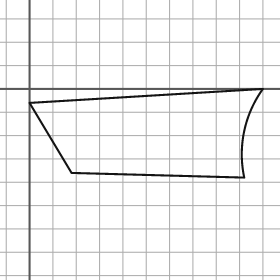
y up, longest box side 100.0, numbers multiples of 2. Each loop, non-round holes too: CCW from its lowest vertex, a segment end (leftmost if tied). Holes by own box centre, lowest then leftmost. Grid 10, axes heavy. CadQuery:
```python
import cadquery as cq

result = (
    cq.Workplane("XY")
    .moveTo(92.0, -38.0)
    .threePointArc((92.0, -18.0), (100.0, 0.0))
    .lineTo(0.0, -6.0)
    .lineTo(18.0, -36.0)
    .close()
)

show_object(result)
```